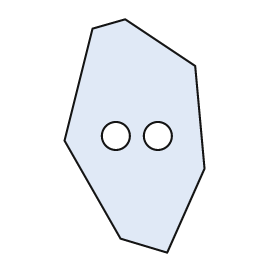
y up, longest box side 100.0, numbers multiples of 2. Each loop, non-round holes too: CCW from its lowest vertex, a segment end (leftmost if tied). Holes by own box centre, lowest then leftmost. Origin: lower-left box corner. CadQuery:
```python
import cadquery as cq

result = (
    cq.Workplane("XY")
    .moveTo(44.0, 0.0)
    .lineTo(60.0, 36.0)
    .lineTo(56.0, 80.0)
    .lineTo(26.0, 100.0)
    .lineTo(12.0, 96.0)
    .lineTo(0.0, 48.0)
    .lineTo(24.0, 6.0)
    .close()
    .moveTo(22.0, 50.0)
    .circle(6.0)
    .moveTo(40.0, 50.0)
    .circle(6.0)
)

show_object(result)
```